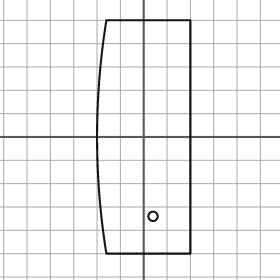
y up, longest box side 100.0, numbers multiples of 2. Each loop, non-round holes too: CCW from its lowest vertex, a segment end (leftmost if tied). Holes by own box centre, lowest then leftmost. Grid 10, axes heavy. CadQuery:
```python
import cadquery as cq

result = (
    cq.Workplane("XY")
    .moveTo(-16.0, -50.0)
    .lineTo(20.0, -50.0)
    .lineTo(20.0, 50.0)
    .lineTo(-16.0, 50.0)
    .threePointArc((-20.0, 0.0), (-16.0, -50.0))
    .close()
    .moveTo(4.0, -34.0)
    .circle(2.0)
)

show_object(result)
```